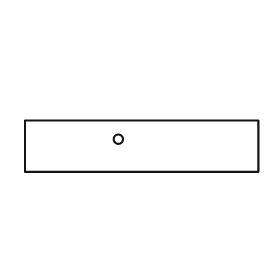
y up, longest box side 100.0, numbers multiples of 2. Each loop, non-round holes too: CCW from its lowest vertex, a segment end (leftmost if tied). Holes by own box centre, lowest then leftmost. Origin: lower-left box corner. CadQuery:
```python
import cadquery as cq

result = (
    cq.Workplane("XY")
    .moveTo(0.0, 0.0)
    .lineTo(100.0, 0.0)
    .lineTo(100.0, 22.0)
    .lineTo(0.0, 22.0)
    .close()
    .moveTo(40.0, 14.0)
    .circle(2.0)
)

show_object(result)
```